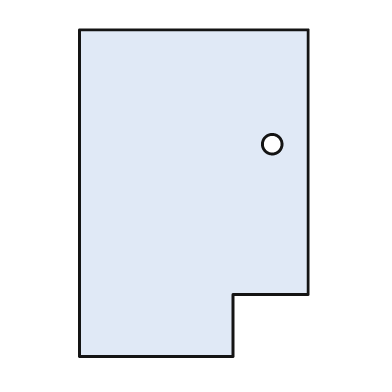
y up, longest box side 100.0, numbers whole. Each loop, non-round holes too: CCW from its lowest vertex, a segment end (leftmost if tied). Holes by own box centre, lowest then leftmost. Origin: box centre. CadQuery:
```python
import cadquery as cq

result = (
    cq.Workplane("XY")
    .moveTo(-35.0, -50.0)
    .lineTo(12.0, -50.0)
    .lineTo(12.0, -31.0)
    .lineTo(35.0, -31.0)
    .lineTo(35.0, 50.0)
    .lineTo(-35.0, 50.0)
    .close()
    .moveTo(24.0, 15.0)
    .circle(3.0)
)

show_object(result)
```